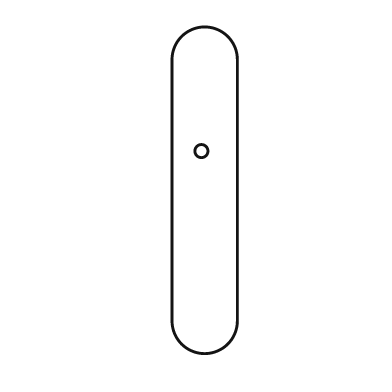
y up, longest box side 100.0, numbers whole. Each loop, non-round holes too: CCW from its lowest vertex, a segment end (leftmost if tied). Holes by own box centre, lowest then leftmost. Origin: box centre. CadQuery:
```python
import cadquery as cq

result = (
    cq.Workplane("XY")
    .moveTo(-10.0, -40.0)
    .threePointArc((0.0, -50.0), (10.0, -40.0))
    .lineTo(10.0, 40.0)
    .threePointArc((0.0, 50.0), (-10.0, 40.0))
    .close()
    .moveTo(-1.0, 12.0)
    .circle(2.0)
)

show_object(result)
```